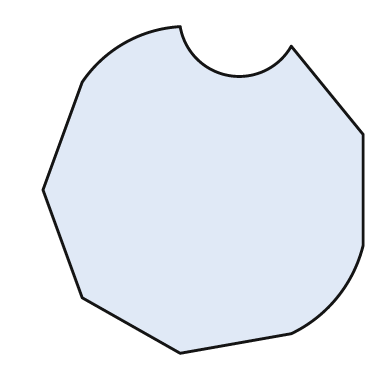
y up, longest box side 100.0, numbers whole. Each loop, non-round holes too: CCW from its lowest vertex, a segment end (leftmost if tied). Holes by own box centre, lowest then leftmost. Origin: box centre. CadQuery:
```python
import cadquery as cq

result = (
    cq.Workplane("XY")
    .moveTo(-7.0, -50.0)
    .lineTo(27.0, -44.0)
    .threePointArc((41.0, -33.0), (49.0, -17.0))
    .lineTo(49.0, 17.0)
    .lineTo(27.0, 44.0)
    .threePointArc((8.0, 35.0), (-7.0, 50.0))
    .threePointArc((-24.0, 45.0), (-37.0, 33.0))
    .lineTo(-49.0, 0.0)
    .lineTo(-37.0, -33.0)
    .close()
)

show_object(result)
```